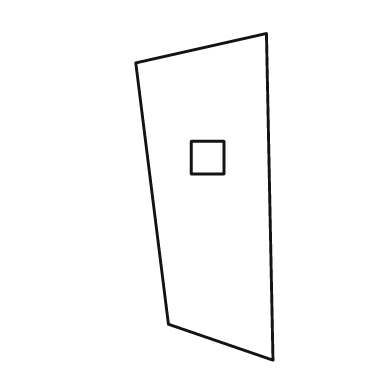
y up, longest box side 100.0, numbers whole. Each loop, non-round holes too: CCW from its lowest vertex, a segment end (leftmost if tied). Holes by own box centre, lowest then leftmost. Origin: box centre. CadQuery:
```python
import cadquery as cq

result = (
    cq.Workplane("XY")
    .moveTo(21.0, -50.0)
    .lineTo(19.0, 50.0)
    .lineTo(-21.0, 41.0)
    .lineTo(-11.0, -39.0)
    .close()
    .moveTo(-4.0, 7.0)
    .lineTo(6.0, 7.0)
    .lineTo(6.0, 17.0)
    .lineTo(-4.0, 17.0)
    .close()
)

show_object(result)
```